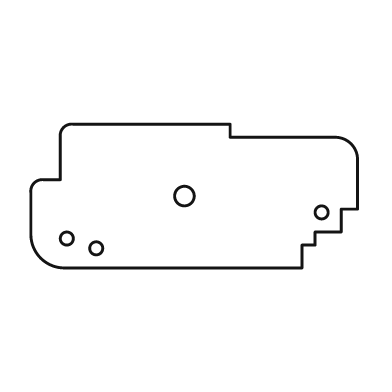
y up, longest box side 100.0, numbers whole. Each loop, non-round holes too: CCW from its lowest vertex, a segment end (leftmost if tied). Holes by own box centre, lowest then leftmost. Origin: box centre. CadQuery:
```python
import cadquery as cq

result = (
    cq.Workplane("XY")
    .moveTo(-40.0, -22.0)
    .lineTo(33.0, -22.0)
    .lineTo(33.0, -15.0)
    .lineTo(37.0, -15.0)
    .lineTo(37.0, -11.0)
    .lineTo(45.0, -11.0)
    .lineTo(45.0, -4.0)
    .lineTo(50.0, -4.0)
    .lineTo(50.0, 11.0)
    .threePointArc((48.0, 16.0), (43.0, 18.0))
    .lineTo(11.0, 18.0)
    .lineTo(11.0, 22.0)
    .lineTo(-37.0, 22.0)
    .threePointArc((-40.0, 21.0), (-41.0, 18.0))
    .lineTo(-41.0, 5.0)
    .lineTo(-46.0, 5.0)
    .threePointArc((-49.0, 4.0), (-50.0, 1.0))
    .lineTo(-50.0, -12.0)
    .threePointArc((-47.0, -19.0), (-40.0, -22.0))
    .close()
    .moveTo(-30.0, -16.0)
    .circle(2.0)
    .moveTo(-39.0, -13.0)
    .circle(2.0)
    .moveTo(39.0, -5.0)
    .circle(2.0)
    .moveTo(-3.0, 0.0)
    .circle(3.0)
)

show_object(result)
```